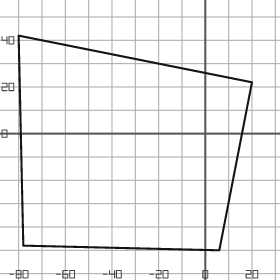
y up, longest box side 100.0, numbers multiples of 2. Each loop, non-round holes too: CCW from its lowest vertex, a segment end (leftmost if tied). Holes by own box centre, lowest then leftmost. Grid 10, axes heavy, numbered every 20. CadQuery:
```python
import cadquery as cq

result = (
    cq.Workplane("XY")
    .moveTo(6.0, -50.0)
    .lineTo(20.0, 22.0)
    .lineTo(-80.0, 42.0)
    .lineTo(-78.0, -48.0)
    .close()
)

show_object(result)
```